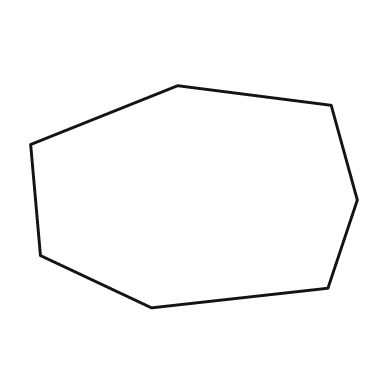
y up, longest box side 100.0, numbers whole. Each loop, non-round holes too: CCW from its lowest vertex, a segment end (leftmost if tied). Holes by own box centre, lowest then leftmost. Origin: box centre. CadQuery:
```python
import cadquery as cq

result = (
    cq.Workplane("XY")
    .moveTo(-13.0, -34.0)
    .lineTo(41.0, -28.0)
    .lineTo(50.0, -1.0)
    .lineTo(42.0, 28.0)
    .lineTo(-5.0, 34.0)
    .lineTo(-50.0, 16.0)
    .lineTo(-47.0, -18.0)
    .close()
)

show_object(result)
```